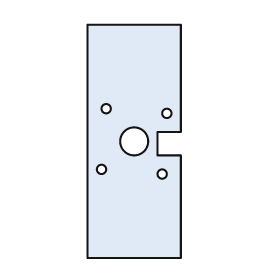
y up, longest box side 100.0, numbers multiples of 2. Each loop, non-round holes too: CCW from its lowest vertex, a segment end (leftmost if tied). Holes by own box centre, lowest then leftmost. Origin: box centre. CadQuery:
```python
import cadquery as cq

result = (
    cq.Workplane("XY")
    .moveTo(-20.0, -50.0)
    .lineTo(20.0, -50.0)
    .lineTo(20.0, -6.0)
    .lineTo(10.0, -6.0)
    .lineTo(10.0, 4.0)
    .lineTo(20.0, 4.0)
    .lineTo(20.0, 50.0)
    .lineTo(-20.0, 50.0)
    .close()
    .moveTo(12.0, -14.0)
    .circle(2.0)
    .moveTo(-14.0, -12.0)
    .circle(2.0)
    .moveTo(0.0, 0.0)
    .circle(6.0)
    .moveTo(14.0, 12.0)
    .circle(2.0)
    .moveTo(-12.0, 14.0)
    .circle(2.0)
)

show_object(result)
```